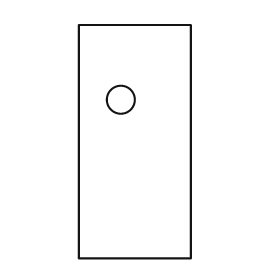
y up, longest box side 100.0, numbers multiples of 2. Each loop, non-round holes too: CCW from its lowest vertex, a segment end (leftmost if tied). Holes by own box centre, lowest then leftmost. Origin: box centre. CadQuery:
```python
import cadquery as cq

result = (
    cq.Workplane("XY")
    .moveTo(-24.0, -50.0)
    .lineTo(24.0, -50.0)
    .lineTo(24.0, 50.0)
    .lineTo(-24.0, 50.0)
    .close()
    .moveTo(-6.0, 18.0)
    .circle(6.0)
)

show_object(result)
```